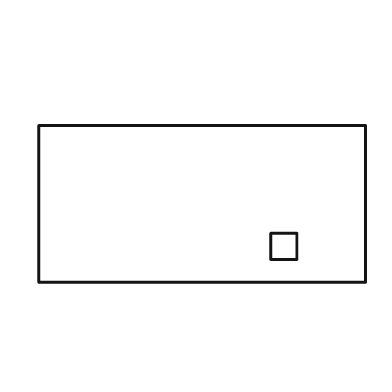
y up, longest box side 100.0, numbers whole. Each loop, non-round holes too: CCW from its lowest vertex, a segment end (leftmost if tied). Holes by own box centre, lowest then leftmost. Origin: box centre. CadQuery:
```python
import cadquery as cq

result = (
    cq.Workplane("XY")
    .moveTo(-50.0, -24.0)
    .lineTo(50.0, -24.0)
    .lineTo(50.0, 24.0)
    .lineTo(-50.0, 24.0)
    .close()
    .moveTo(21.0, -17.0)
    .lineTo(29.0, -17.0)
    .lineTo(29.0, -9.0)
    .lineTo(21.0, -9.0)
    .close()
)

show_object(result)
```